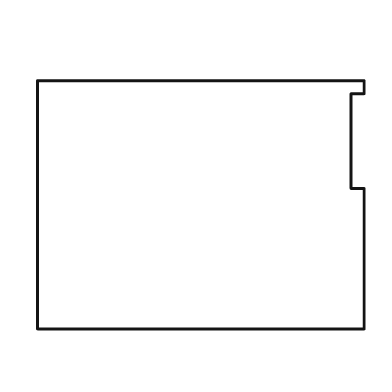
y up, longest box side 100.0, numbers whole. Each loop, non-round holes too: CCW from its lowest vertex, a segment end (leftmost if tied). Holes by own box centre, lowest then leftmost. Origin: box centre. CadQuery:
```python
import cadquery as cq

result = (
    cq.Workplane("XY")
    .moveTo(-50.0, -38.0)
    .lineTo(50.0, -38.0)
    .lineTo(50.0, 5.0)
    .lineTo(46.0, 5.0)
    .lineTo(46.0, 34.0)
    .lineTo(50.0, 34.0)
    .lineTo(50.0, 38.0)
    .lineTo(-50.0, 38.0)
    .close()
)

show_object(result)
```